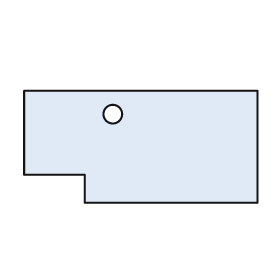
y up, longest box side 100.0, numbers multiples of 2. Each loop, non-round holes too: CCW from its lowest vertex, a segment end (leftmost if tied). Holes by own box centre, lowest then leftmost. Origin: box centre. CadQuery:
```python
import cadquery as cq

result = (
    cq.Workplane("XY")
    .moveTo(-24.0, -24.0)
    .lineTo(50.0, -24.0)
    .lineTo(50.0, 24.0)
    .lineTo(-50.0, 24.0)
    .lineTo(-50.0, -12.0)
    .lineTo(-24.0, -12.0)
    .close()
    .moveTo(-12.0, 14.0)
    .circle(4.0)
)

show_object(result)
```